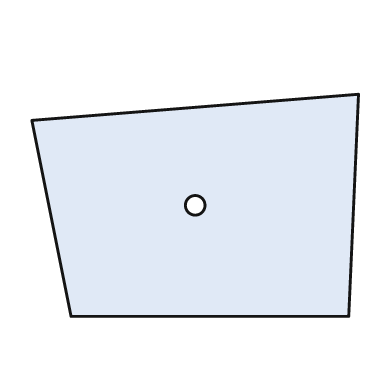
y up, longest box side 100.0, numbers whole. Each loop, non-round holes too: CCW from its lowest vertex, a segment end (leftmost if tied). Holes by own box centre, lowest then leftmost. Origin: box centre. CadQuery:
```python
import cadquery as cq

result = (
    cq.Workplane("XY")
    .moveTo(-38.0, -34.0)
    .lineTo(47.0, -34.0)
    .lineTo(50.0, 34.0)
    .lineTo(-50.0, 26.0)
    .close()
    .moveTo(0.0, 0.0)
    .circle(3.0)
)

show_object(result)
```